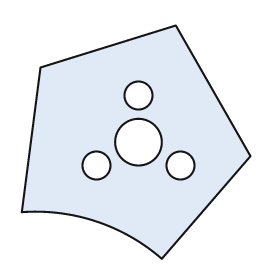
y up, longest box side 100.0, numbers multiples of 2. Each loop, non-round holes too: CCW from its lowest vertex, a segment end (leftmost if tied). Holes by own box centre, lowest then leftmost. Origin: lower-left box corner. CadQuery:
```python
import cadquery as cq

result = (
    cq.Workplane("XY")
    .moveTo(60.0, 0.0)
    .lineTo(98.0, 44.0)
    .lineTo(66.0, 100.0)
    .lineTo(8.0, 82.0)
    .lineTo(0.0, 20.0)
    .threePointArc((32.0, 16.0), (60.0, 0.0))
    .close()
    .moveTo(32.0, 40.0)
    .circle(6.0)
    .moveTo(68.0, 40.0)
    .circle(6.0)
    .moveTo(50.0, 50.0)
    .circle(10.0)
    .moveTo(50.0, 70.0)
    .circle(6.0)
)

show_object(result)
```